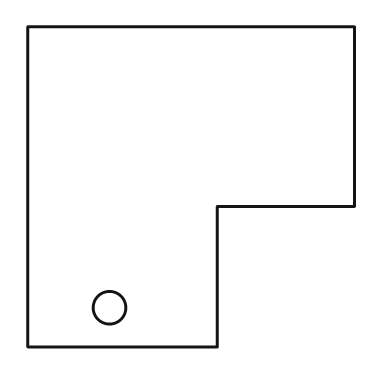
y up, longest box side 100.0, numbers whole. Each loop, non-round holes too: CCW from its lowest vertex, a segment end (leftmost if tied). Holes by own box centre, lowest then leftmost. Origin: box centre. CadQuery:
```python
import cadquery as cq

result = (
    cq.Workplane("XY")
    .moveTo(-50.0, -49.0)
    .lineTo(8.0, -49.0)
    .lineTo(8.0, -6.0)
    .lineTo(50.0, -6.0)
    .lineTo(50.0, 49.0)
    .lineTo(-50.0, 49.0)
    .close()
    .moveTo(-25.0, -37.0)
    .circle(5.0)
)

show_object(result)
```